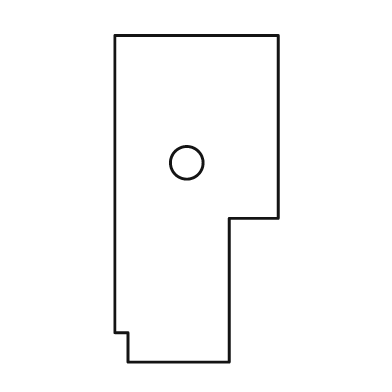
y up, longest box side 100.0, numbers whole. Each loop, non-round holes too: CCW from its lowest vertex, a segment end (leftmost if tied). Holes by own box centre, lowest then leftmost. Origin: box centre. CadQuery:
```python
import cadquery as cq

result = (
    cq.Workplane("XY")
    .moveTo(-21.0, -50.0)
    .lineTo(10.0, -50.0)
    .lineTo(10.0, -6.0)
    .lineTo(25.0, -6.0)
    .lineTo(25.0, 50.0)
    .lineTo(-25.0, 50.0)
    .lineTo(-25.0, -41.0)
    .lineTo(-21.0, -41.0)
    .close()
    .moveTo(-3.0, 11.0)
    .circle(5.0)
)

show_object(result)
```